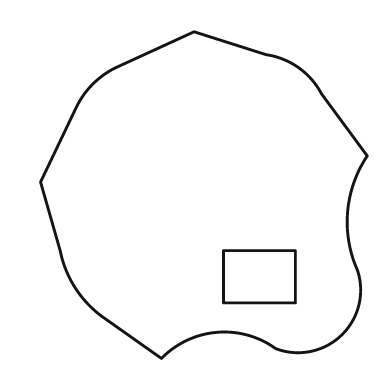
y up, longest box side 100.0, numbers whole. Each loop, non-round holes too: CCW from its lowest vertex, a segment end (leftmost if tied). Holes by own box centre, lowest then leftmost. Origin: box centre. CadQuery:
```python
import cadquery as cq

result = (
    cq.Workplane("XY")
    .moveTo(-13.0, -50.0)
    .threePointArc((4.0, -42.0), (22.0, -47.0))
    .threePointArc((42.0, -43.0), (47.0, -23.0))
    .threePointArc((44.0, -5.0), (50.0, 12.0))
    .lineTo(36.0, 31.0)
    .threePointArc((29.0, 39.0), (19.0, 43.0))
    .lineTo(-3.0, 50.0)
    .lineTo(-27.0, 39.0)
    .threePointArc((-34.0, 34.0), (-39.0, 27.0))
    .lineTo(-50.0, 4.0)
    .lineTo(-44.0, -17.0)
    .threePointArc((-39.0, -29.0), (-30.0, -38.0))
    .close()
    .moveTo(6.0, -33.0)
    .lineTo(28.0, -33.0)
    .lineTo(28.0, -17.0)
    .lineTo(6.0, -17.0)
    .close()
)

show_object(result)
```